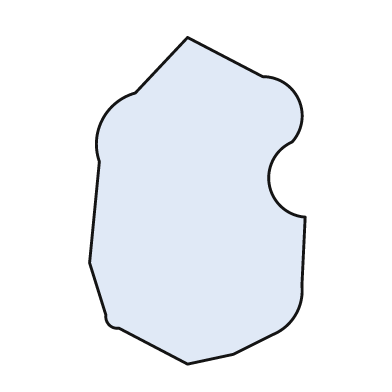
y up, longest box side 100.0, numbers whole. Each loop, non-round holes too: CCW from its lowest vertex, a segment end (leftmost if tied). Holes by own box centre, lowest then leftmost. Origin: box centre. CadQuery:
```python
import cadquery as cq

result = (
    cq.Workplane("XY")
    .moveTo(-3.0, -50.0)
    .lineTo(11.0, -47.0)
    .lineTo(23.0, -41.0)
    .threePointArc((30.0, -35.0), (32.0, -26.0))
    .lineTo(33.0, -5.0)
    .threePointArc((22.0, 5.0), (29.0, 18.0))
    .threePointArc((31.0, 31.0), (20.0, 38.0))
    .lineTo(-3.0, 50.0)
    .lineTo(-19.0, 33.0)
    .threePointArc((-29.0, 25.0), (-30.0, 12.0))
    .lineTo(-33.0, -19.0)
    .lineTo(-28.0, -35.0)
    .threePointArc((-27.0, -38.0), (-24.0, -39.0))
    .close()
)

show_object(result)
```